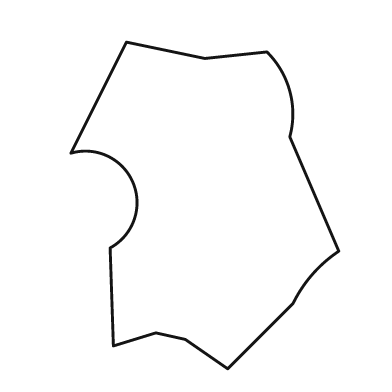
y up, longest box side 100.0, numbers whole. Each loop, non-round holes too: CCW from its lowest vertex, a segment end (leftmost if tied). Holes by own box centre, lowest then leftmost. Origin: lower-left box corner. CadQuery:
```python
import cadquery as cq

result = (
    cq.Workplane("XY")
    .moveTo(48.0, 0.0)
    .lineTo(68.0, 20.0)
    .threePointArc((74.0, 29.0), (82.0, 36.0))
    .lineTo(67.0, 71.0)
    .threePointArc((67.0, 85.0), (60.0, 97.0))
    .lineTo(41.0, 95.0)
    .lineTo(17.0, 100.0)
    .lineTo(0.0, 66.0)
    .threePointArc((19.0, 57.0), (12.0, 37.0))
    .lineTo(13.0, 7.0)
    .lineTo(26.0, 11.0)
    .lineTo(35.0, 9.0)
    .close()
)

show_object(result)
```